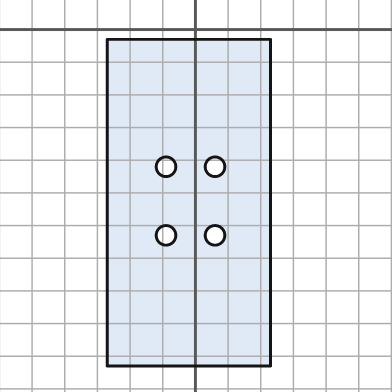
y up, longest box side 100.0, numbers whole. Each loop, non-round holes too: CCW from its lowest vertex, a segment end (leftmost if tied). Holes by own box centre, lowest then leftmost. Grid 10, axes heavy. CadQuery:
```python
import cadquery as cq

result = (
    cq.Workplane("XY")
    .moveTo(-27.0, -103.0)
    .lineTo(23.0, -103.0)
    .lineTo(23.0, -3.0)
    .lineTo(-27.0, -3.0)
    .close()
    .moveTo(-9.0, -63.0)
    .circle(3.0)
    .moveTo(6.0, -63.0)
    .circle(3.0)
    .moveTo(-9.0, -42.0)
    .circle(3.0)
    .moveTo(6.0, -42.0)
    .circle(3.0)
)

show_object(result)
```